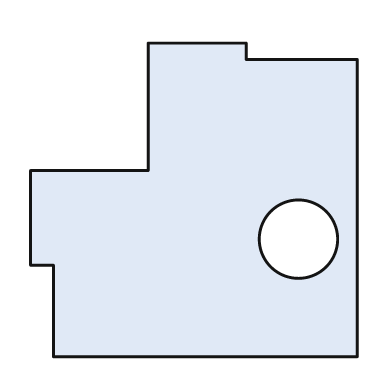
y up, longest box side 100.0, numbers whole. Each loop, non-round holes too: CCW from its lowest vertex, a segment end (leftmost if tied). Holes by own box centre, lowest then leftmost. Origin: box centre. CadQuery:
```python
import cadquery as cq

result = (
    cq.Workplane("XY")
    .moveTo(-43.0, -48.0)
    .lineTo(50.0, -48.0)
    .lineTo(50.0, 43.0)
    .lineTo(16.0, 43.0)
    .lineTo(16.0, 48.0)
    .lineTo(-14.0, 48.0)
    .lineTo(-14.0, 9.0)
    .lineTo(-50.0, 9.0)
    .lineTo(-50.0, -20.0)
    .lineTo(-43.0, -20.0)
    .close()
    .moveTo(32.0, -12.0)
    .circle(12.0)
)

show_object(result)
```